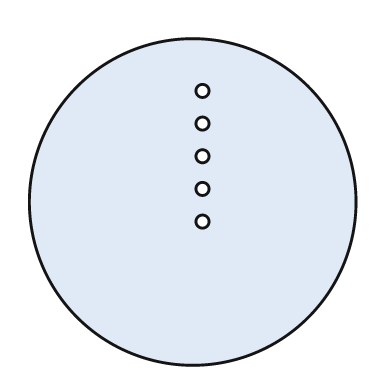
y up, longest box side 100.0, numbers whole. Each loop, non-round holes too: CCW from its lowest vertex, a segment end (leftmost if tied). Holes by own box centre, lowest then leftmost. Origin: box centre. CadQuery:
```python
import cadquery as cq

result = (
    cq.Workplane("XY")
    .moveTo(0.0, 0.0)
    .circle(50.0)
    .moveTo(3.0, -6.0)
    .circle(2.0)
    .moveTo(3.0, 4.0)
    .circle(2.0)
    .moveTo(3.0, 14.0)
    .circle(2.0)
    .moveTo(3.0, 24.0)
    .circle(2.0)
    .moveTo(3.0, 34.0)
    .circle(2.0)
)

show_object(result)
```